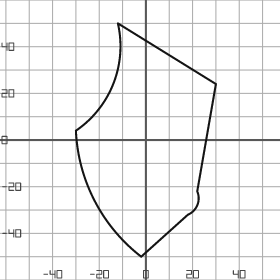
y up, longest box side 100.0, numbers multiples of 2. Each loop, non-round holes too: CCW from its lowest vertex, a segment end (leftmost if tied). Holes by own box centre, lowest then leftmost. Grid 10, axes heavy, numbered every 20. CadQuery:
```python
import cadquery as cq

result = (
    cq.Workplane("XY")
    .moveTo(-2.0, -50.0)
    .lineTo(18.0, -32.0)
    .threePointArc((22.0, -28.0), (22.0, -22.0))
    .lineTo(30.0, 24.0)
    .lineTo(-12.0, 50.0)
    .threePointArc((-14.0, 24.0), (-30.0, 4.0))
    .threePointArc((-22.0, -26.0), (-2.0, -50.0))
    .close()
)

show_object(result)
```